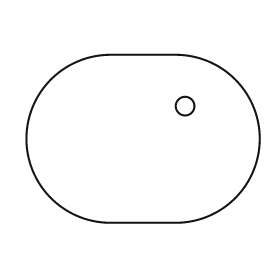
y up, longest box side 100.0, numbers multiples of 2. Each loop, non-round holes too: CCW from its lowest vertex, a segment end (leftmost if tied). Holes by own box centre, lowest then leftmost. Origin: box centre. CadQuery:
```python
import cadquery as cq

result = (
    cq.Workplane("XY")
    .moveTo(-14.0, -36.0)
    .lineTo(14.0, -36.0)
    .threePointArc((50.0, 0.0), (14.0, 36.0))
    .lineTo(-14.0, 36.0)
    .threePointArc((-50.0, 0.0), (-14.0, -36.0))
    .close()
    .moveTo(18.0, 14.0)
    .circle(4.0)
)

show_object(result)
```